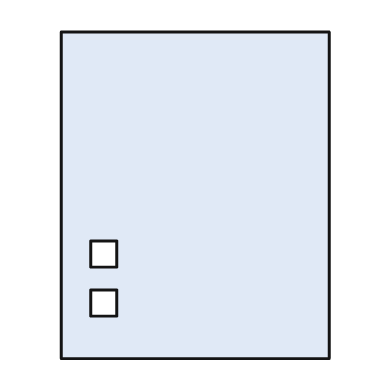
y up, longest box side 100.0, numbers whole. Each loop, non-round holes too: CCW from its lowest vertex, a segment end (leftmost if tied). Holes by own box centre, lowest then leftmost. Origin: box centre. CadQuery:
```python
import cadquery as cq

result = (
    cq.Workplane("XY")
    .moveTo(-41.0, -50.0)
    .lineTo(41.0, -50.0)
    .lineTo(41.0, 50.0)
    .lineTo(-41.0, 50.0)
    .close()
    .moveTo(-32.0, -37.0)
    .lineTo(-24.0, -37.0)
    .lineTo(-24.0, -29.0)
    .lineTo(-32.0, -29.0)
    .close()
    .moveTo(-32.0, -22.0)
    .lineTo(-24.0, -22.0)
    .lineTo(-24.0, -14.0)
    .lineTo(-32.0, -14.0)
    .close()
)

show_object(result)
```